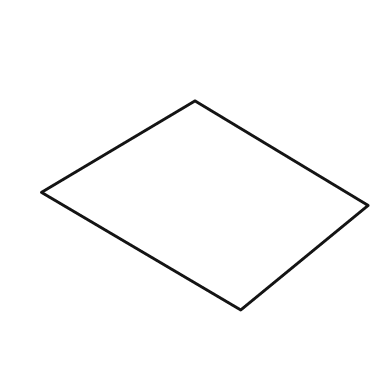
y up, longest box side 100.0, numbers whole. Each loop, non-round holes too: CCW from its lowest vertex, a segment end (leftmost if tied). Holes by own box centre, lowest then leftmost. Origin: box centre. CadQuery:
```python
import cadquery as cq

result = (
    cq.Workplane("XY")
    .moveTo(11.0, -32.0)
    .lineTo(50.0, 0.0)
    .lineTo(-3.0, 32.0)
    .lineTo(-50.0, 4.0)
    .close()
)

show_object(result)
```